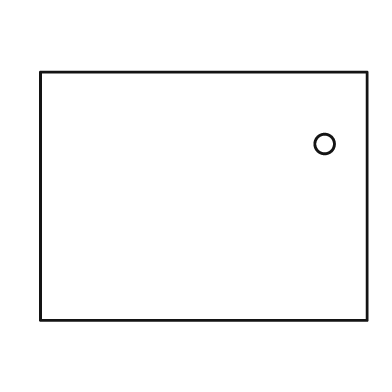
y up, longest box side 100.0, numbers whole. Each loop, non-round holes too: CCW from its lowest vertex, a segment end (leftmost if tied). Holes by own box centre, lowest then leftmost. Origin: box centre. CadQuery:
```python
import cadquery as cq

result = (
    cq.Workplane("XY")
    .moveTo(-50.0, -38.0)
    .lineTo(50.0, -38.0)
    .lineTo(50.0, 38.0)
    .lineTo(-50.0, 38.0)
    .close()
    .moveTo(37.0, 16.0)
    .circle(3.0)
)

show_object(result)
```